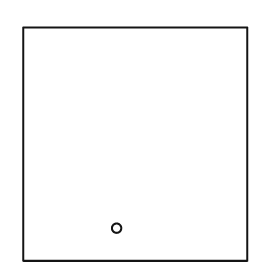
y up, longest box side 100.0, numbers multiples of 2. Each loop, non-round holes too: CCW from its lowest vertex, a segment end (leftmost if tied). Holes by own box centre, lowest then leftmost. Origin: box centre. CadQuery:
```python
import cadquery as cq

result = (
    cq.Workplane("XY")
    .moveTo(-48.0, -50.0)
    .lineTo(48.0, -50.0)
    .lineTo(48.0, 50.0)
    .lineTo(-48.0, 50.0)
    .close()
    .moveTo(-8.0, -36.0)
    .circle(2.0)
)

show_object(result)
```